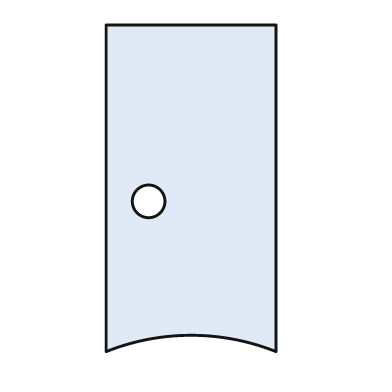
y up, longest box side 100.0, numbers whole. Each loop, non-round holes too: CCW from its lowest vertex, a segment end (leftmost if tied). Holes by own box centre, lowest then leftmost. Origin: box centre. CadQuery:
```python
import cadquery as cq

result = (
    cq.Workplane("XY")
    .moveTo(-26.0, -50.0)
    .threePointArc((0.0, -45.0), (26.0, -50.0))
    .lineTo(26.0, 50.0)
    .lineTo(-26.0, 50.0)
    .close()
    .moveTo(-13.0, -4.0)
    .circle(5.0)
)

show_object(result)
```